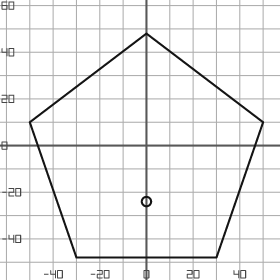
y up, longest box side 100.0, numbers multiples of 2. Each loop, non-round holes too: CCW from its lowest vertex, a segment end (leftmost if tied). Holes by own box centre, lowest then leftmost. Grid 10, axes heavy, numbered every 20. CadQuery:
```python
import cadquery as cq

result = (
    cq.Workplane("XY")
    .moveTo(-30.0, -48.0)
    .lineTo(30.0, -48.0)
    .lineTo(50.0, 10.0)
    .lineTo(0.0, 48.0)
    .lineTo(-50.0, 10.0)
    .close()
    .moveTo(0.0, -24.0)
    .circle(2.0)
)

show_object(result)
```